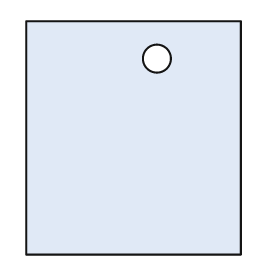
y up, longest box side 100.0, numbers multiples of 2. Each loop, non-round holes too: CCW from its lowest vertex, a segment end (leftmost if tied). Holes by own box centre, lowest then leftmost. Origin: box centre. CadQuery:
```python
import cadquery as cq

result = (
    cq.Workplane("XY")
    .moveTo(-46.0, -50.0)
    .lineTo(46.0, -50.0)
    .lineTo(46.0, 50.0)
    .lineTo(-46.0, 50.0)
    .close()
    .moveTo(10.0, 34.0)
    .circle(6.0)
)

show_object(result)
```